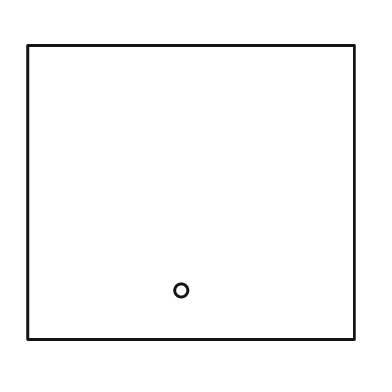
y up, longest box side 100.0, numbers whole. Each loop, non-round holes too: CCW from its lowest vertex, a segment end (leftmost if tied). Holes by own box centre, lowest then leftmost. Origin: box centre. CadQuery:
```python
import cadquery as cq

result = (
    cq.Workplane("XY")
    .moveTo(-50.0, -45.0)
    .lineTo(50.0, -45.0)
    .lineTo(50.0, 45.0)
    .lineTo(-50.0, 45.0)
    .close()
    .moveTo(-3.0, -30.0)
    .circle(2.0)
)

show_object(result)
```